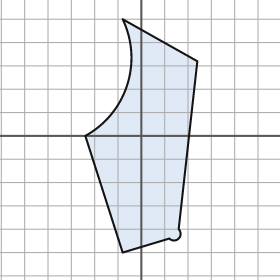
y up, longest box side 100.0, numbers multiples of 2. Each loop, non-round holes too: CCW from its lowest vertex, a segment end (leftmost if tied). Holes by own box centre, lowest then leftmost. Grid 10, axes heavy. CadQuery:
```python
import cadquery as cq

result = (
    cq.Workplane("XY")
    .moveTo(-8.0, -50.0)
    .lineTo(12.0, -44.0)
    .threePointArc((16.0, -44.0), (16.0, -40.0))
    .lineTo(24.0, 32.0)
    .lineTo(-8.0, 50.0)
    .threePointArc((-6.0, 22.0), (-24.0, 0.0))
    .close()
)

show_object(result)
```